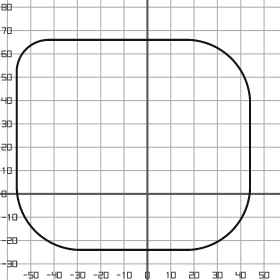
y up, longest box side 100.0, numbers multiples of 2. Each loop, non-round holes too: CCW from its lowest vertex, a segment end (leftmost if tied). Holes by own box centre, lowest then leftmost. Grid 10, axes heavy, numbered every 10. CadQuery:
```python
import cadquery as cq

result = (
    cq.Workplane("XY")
    .moveTo(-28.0, -24.0)
    .lineTo(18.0, -24.0)
    .threePointArc((36.0, -16.0), (44.0, 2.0))
    .lineTo(44.0, 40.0)
    .threePointArc((36.0, 58.0), (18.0, 66.0))
    .lineTo(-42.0, 66.0)
    .threePointArc((-52.0, 62.0), (-56.0, 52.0))
    .lineTo(-56.0, 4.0)
    .threePointArc((-48.0, -16.0), (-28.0, -24.0))
    .close()
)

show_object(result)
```